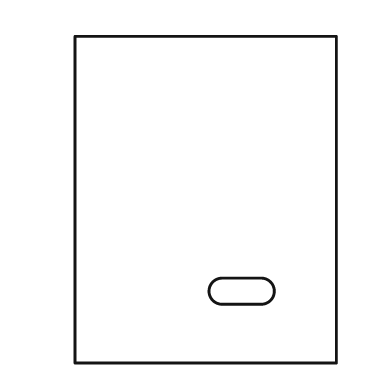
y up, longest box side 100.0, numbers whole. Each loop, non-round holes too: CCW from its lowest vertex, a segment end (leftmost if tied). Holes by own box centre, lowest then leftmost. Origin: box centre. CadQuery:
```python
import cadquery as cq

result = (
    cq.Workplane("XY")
    .moveTo(-40.0, -50.0)
    .lineTo(40.0, -50.0)
    .lineTo(40.0, 50.0)
    .lineTo(-40.0, 50.0)
    .close()
    .moveTo(5.0, -32.0)
    .lineTo(17.0, -32.0)
    .threePointArc((21.0, -28.0), (17.0, -24.0))
    .lineTo(5.0, -24.0)
    .threePointArc((1.0, -28.0), (5.0, -32.0))
    .close()
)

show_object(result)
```